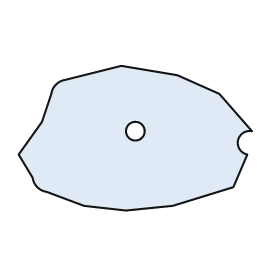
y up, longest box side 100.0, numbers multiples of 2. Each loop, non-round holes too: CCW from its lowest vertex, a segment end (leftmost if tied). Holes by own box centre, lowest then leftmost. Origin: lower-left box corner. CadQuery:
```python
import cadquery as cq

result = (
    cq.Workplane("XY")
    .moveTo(46.0, 0.0)
    .lineTo(66.0, 2.0)
    .lineTo(92.0, 10.0)
    .lineTo(98.0, 24.0)
    .threePointArc((94.0, 30.0), (100.0, 34.0))
    .lineTo(86.0, 50.0)
    .lineTo(68.0, 58.0)
    .lineTo(44.0, 62.0)
    .lineTo(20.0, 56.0)
    .threePointArc((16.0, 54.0), (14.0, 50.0))
    .lineTo(10.0, 38.0)
    .lineTo(0.0, 24.0)
    .lineTo(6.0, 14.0)
    .threePointArc((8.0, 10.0), (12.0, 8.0))
    .lineTo(28.0, 2.0)
    .close()
    .moveTo(50.0, 34.0)
    .circle(4.0)
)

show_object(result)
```